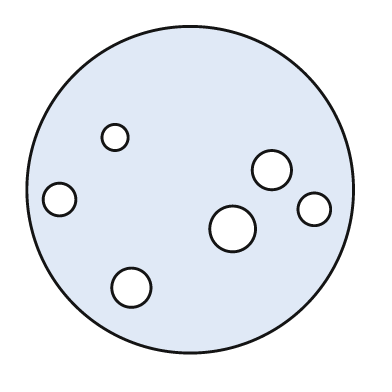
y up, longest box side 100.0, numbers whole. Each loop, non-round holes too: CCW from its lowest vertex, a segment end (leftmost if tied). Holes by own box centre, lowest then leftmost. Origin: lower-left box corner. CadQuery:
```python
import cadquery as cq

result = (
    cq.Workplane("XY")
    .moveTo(50.0, 50.0)
    .circle(50.0)
    .moveTo(32.0, 20.0)
    .circle(6.0)
    .moveTo(63.0, 38.0)
    .circle(7.0)
    .moveTo(88.0, 44.0)
    .circle(5.0)
    .moveTo(10.0, 47.0)
    .circle(5.0)
    .moveTo(75.0, 56.0)
    .circle(6.0)
    .moveTo(27.0, 66.0)
    .circle(4.0)
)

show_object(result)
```